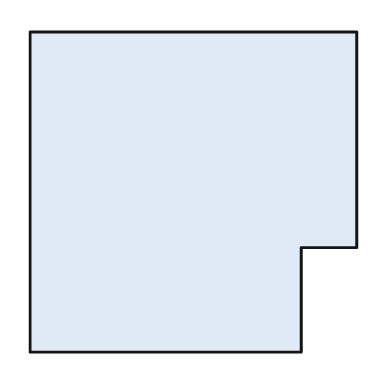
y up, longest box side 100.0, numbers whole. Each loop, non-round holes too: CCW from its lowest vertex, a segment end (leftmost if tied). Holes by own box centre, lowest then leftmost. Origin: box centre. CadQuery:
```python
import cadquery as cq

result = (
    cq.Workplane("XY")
    .moveTo(-50.0, -49.0)
    .lineTo(33.0, -49.0)
    .lineTo(33.0, -17.0)
    .lineTo(50.0, -17.0)
    .lineTo(50.0, 49.0)
    .lineTo(-50.0, 49.0)
    .close()
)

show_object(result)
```